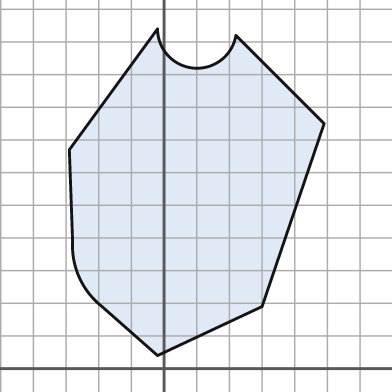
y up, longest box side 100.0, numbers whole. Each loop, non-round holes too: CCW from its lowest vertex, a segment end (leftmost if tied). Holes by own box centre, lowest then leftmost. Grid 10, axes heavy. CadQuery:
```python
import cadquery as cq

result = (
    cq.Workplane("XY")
    .moveTo(-2.0, 4.0)
    .lineTo(30.0, 19.0)
    .lineTo(49.0, 75.0)
    .lineTo(22.0, 102.0)
    .threePointArc((9.0, 92.0), (-2.0, 104.0))
    .lineTo(-29.0, 67.0)
    .lineTo(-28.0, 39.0)
    .threePointArc((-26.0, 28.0), (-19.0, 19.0))
    .close()
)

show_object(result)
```